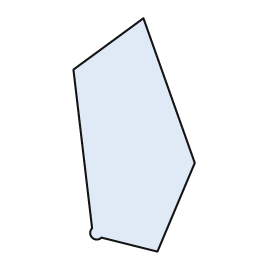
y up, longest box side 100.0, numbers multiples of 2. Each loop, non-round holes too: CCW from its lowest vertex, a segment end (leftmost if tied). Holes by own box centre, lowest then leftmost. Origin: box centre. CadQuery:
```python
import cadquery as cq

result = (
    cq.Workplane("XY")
    .moveTo(10.0, -50.0)
    .lineTo(26.0, -12.0)
    .lineTo(4.0, 50.0)
    .lineTo(-26.0, 28.0)
    .lineTo(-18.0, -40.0)
    .threePointArc((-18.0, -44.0), (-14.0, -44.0))
    .close()
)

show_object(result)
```